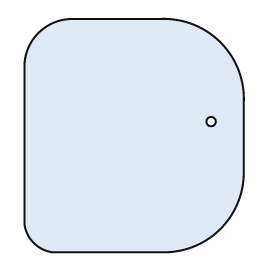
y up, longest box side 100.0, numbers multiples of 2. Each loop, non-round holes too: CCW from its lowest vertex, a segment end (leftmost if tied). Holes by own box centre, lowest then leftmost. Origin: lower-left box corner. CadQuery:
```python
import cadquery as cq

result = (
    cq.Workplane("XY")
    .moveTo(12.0, 0.0)
    .lineTo(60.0, 0.0)
    .threePointArc((84.0, 10.0), (94.0, 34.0))
    .lineTo(94.0, 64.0)
    .threePointArc((84.0, 90.0), (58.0, 100.0))
    .lineTo(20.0, 100.0)
    .threePointArc((6.0, 94.0), (0.0, 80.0))
    .lineTo(0.0, 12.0)
    .threePointArc((4.0, 4.0), (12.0, 0.0))
    .close()
    .moveTo(80.0, 56.0)
    .circle(2.0)
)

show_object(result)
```